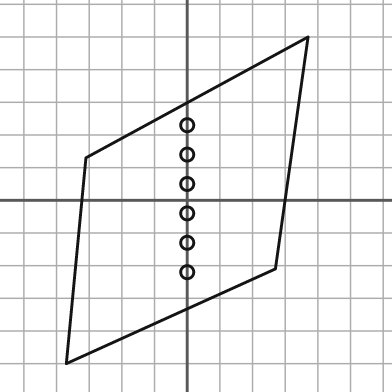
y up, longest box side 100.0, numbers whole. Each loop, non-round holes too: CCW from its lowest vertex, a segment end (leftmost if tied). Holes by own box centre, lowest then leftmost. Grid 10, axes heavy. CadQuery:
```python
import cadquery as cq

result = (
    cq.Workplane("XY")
    .moveTo(-37.0, -50.0)
    .lineTo(27.0, -21.0)
    .lineTo(37.0, 50.0)
    .lineTo(-31.0, 13.0)
    .close()
    .moveTo(0.0, -22.0)
    .circle(2.0)
    .moveTo(0.0, -13.0)
    .circle(2.0)
    .moveTo(0.0, -4.0)
    .circle(2.0)
    .moveTo(0.0, 5.0)
    .circle(2.0)
    .moveTo(0.0, 14.0)
    .circle(2.0)
    .moveTo(0.0, 23.0)
    .circle(2.0)
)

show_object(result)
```